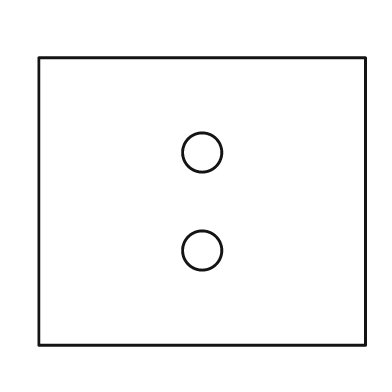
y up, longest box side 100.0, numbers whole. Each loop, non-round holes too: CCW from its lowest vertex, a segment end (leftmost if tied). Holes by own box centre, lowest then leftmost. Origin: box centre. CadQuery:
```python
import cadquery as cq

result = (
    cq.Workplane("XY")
    .moveTo(-50.0, -44.0)
    .lineTo(50.0, -44.0)
    .lineTo(50.0, 44.0)
    .lineTo(-50.0, 44.0)
    .close()
    .moveTo(0.0, -15.0)
    .circle(6.0)
    .moveTo(0.0, 15.0)
    .circle(6.0)
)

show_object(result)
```